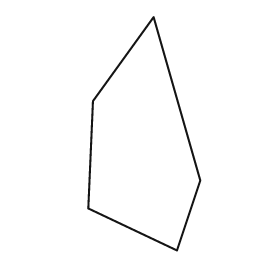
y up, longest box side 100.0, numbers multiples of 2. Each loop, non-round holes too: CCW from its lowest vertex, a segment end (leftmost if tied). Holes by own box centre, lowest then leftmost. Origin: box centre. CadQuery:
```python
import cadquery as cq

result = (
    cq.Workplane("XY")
    .moveTo(14.0, -50.0)
    .lineTo(24.0, -20.0)
    .lineTo(4.0, 50.0)
    .lineTo(-22.0, 14.0)
    .lineTo(-24.0, -32.0)
    .close()
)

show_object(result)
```